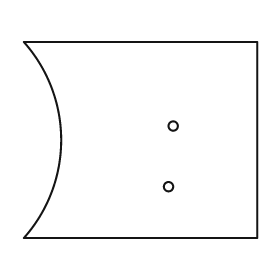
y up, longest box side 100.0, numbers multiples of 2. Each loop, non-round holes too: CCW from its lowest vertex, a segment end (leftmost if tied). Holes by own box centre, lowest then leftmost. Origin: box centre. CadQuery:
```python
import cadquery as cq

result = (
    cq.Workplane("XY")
    .moveTo(-50.0, -42.0)
    .lineTo(50.0, -42.0)
    .lineTo(50.0, 42.0)
    .lineTo(-50.0, 42.0)
    .threePointArc((-34.0, 0.0), (-50.0, -42.0))
    .close()
    .moveTo(12.0, -20.0)
    .circle(2.0)
    .moveTo(14.0, 6.0)
    .circle(2.0)
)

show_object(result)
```